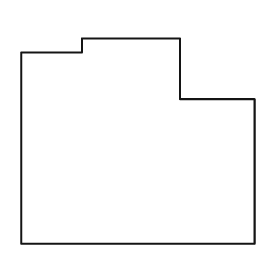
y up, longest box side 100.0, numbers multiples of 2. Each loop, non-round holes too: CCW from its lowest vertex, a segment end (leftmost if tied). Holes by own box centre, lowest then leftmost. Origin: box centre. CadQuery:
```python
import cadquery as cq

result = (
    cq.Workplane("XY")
    .moveTo(-50.0, -44.0)
    .lineTo(50.0, -44.0)
    .lineTo(50.0, 18.0)
    .lineTo(18.0, 18.0)
    .lineTo(18.0, 44.0)
    .lineTo(-24.0, 44.0)
    .lineTo(-24.0, 38.0)
    .lineTo(-50.0, 38.0)
    .close()
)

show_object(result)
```